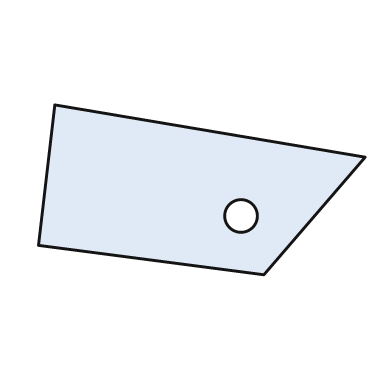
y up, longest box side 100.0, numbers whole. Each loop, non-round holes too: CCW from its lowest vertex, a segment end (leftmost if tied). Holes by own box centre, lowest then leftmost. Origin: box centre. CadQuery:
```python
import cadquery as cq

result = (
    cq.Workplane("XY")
    .moveTo(19.0, -26.0)
    .lineTo(50.0, 10.0)
    .lineTo(-45.0, 26.0)
    .lineTo(-50.0, -17.0)
    .close()
    .moveTo(12.0, -8.0)
    .circle(5.0)
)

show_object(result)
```